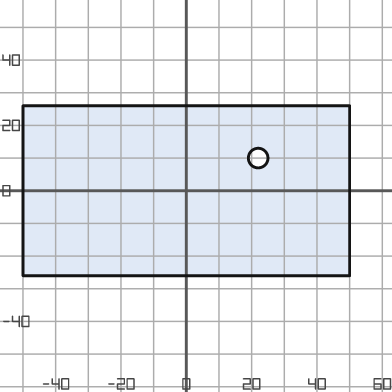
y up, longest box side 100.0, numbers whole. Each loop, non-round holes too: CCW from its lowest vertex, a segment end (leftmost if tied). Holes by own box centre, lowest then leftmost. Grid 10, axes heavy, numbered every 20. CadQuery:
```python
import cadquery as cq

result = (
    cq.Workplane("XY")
    .moveTo(-50.0, -26.0)
    .lineTo(50.0, -26.0)
    .lineTo(50.0, 26.0)
    .lineTo(-50.0, 26.0)
    .close()
    .moveTo(22.0, 10.0)
    .circle(3.0)
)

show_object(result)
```